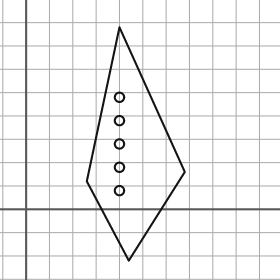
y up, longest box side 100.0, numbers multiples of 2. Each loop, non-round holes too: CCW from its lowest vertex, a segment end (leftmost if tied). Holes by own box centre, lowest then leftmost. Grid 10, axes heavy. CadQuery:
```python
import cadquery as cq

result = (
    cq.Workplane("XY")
    .moveTo(44.0, -22.0)
    .lineTo(68.0, 16.0)
    .lineTo(40.0, 78.0)
    .lineTo(26.0, 12.0)
    .close()
    .moveTo(40.0, 8.0)
    .circle(2.0)
    .moveTo(40.0, 18.0)
    .circle(2.0)
    .moveTo(40.0, 28.0)
    .circle(2.0)
    .moveTo(40.0, 38.0)
    .circle(2.0)
    .moveTo(40.0, 48.0)
    .circle(2.0)
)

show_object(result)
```